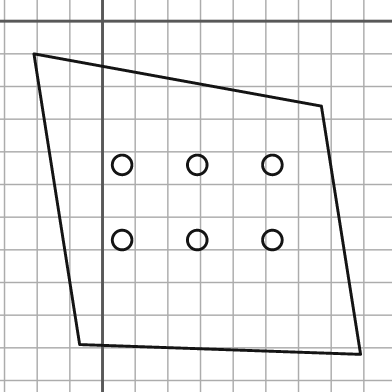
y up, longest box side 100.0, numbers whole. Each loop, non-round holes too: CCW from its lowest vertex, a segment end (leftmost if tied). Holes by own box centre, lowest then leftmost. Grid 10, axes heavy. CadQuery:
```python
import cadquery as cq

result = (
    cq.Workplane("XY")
    .moveTo(79.0, -102.0)
    .lineTo(67.0, -26.0)
    .lineTo(-21.0, -10.0)
    .lineTo(-7.0, -99.0)
    .close()
    .moveTo(6.0, -67.0)
    .circle(3.0)
    .moveTo(29.0, -67.0)
    .circle(3.0)
    .moveTo(52.0, -67.0)
    .circle(3.0)
    .moveTo(6.0, -44.0)
    .circle(3.0)
    .moveTo(29.0, -44.0)
    .circle(3.0)
    .moveTo(52.0, -44.0)
    .circle(3.0)
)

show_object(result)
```